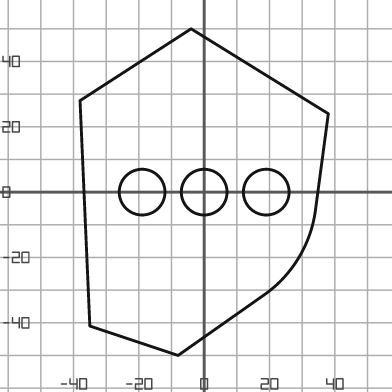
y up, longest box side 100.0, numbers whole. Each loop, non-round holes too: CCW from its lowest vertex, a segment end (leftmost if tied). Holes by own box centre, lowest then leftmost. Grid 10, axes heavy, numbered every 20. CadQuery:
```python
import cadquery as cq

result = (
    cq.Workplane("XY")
    .moveTo(-8.0, -50.0)
    .lineTo(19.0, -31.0)
    .threePointArc((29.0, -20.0), (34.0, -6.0))
    .lineTo(38.0, 24.0)
    .lineTo(-4.0, 50.0)
    .lineTo(-38.0, 28.0)
    .lineTo(-35.0, -41.0)
    .close()
    .moveTo(-19.0, 0.0)
    .circle(7.0)
    .moveTo(0.0, 0.0)
    .circle(7.0)
    .moveTo(19.0, 0.0)
    .circle(7.0)
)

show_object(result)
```